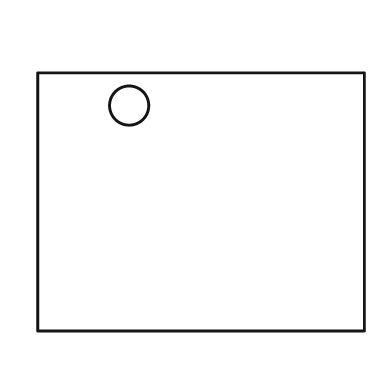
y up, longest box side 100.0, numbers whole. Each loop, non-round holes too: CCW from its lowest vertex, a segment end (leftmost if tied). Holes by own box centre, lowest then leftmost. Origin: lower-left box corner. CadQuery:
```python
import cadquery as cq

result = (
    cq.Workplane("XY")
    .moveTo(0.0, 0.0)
    .lineTo(100.0, 0.0)
    .lineTo(100.0, 79.0)
    .lineTo(0.0, 79.0)
    .close()
    .moveTo(28.0, 69.0)
    .circle(6.0)
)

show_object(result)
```